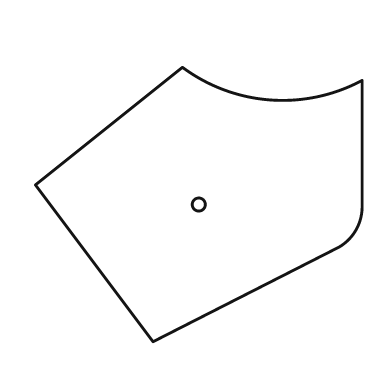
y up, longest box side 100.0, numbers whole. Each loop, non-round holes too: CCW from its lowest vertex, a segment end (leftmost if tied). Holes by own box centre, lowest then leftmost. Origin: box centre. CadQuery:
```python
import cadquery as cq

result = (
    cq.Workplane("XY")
    .moveTo(-14.0, -42.0)
    .lineTo(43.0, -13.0)
    .threePointArc((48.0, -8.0), (50.0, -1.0))
    .lineTo(50.0, 38.0)
    .threePointArc((22.0, 32.0), (-5.0, 42.0))
    .lineTo(-50.0, 6.0)
    .close()
    .moveTo(0.0, 0.0)
    .circle(2.0)
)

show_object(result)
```